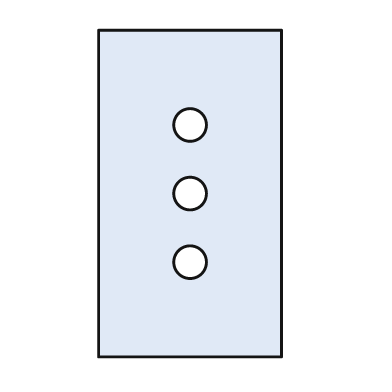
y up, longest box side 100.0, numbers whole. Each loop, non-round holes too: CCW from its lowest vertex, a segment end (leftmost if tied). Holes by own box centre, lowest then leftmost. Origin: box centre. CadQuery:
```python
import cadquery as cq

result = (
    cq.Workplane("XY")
    .moveTo(-28.0, -50.0)
    .lineTo(28.0, -50.0)
    .lineTo(28.0, 50.0)
    .lineTo(-28.0, 50.0)
    .close()
    .moveTo(0.0, -21.0)
    .circle(5.0)
    .moveTo(0.0, 0.0)
    .circle(5.0)
    .moveTo(0.0, 21.0)
    .circle(5.0)
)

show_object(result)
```